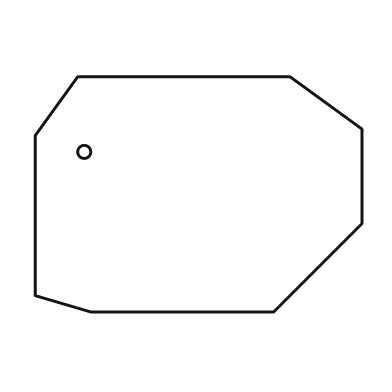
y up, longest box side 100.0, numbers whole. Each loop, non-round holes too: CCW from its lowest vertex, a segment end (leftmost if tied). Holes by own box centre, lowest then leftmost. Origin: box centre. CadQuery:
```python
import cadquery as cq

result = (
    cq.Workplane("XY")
    .moveTo(-33.0, -36.0)
    .lineTo(23.0, -36.0)
    .lineTo(50.0, -9.0)
    .lineTo(50.0, 20.0)
    .lineTo(28.0, 36.0)
    .lineTo(-37.0, 36.0)
    .lineTo(-50.0, 18.0)
    .lineTo(-50.0, -31.0)
    .close()
    .moveTo(-35.0, 13.0)
    .circle(2.0)
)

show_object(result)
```